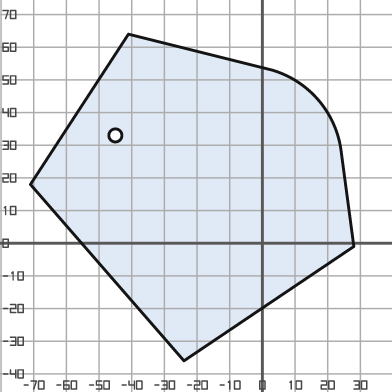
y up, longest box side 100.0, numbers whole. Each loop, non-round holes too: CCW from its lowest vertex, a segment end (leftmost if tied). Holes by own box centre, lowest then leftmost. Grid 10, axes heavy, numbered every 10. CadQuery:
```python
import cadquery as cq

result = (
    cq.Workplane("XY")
    .moveTo(-24.0, -36.0)
    .lineTo(28.0, -1.0)
    .lineTo(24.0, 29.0)
    .threePointArc((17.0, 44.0), (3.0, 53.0))
    .lineTo(-41.0, 64.0)
    .lineTo(-71.0, 18.0)
    .close()
    .moveTo(-45.0, 33.0)
    .circle(2.0)
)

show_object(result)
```